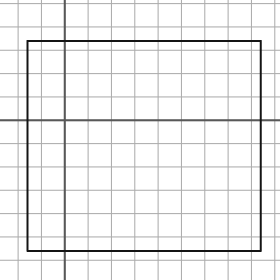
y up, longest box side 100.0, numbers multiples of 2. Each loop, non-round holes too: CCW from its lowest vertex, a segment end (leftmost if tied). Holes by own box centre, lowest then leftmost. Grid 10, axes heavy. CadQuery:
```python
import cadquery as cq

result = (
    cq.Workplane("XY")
    .moveTo(-16.0, -56.0)
    .lineTo(84.0, -56.0)
    .lineTo(84.0, 34.0)
    .lineTo(-16.0, 34.0)
    .close()
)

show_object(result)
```